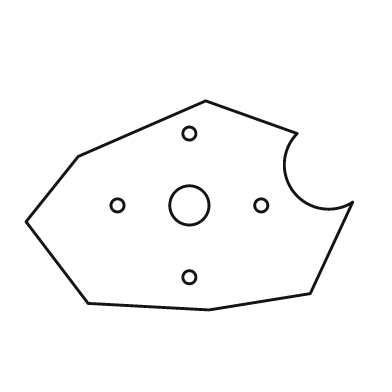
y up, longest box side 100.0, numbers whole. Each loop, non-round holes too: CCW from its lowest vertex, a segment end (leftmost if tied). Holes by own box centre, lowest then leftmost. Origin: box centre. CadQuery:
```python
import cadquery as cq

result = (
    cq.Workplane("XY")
    .moveTo(6.0, -32.0)
    .lineTo(37.0, -27.0)
    .lineTo(50.0, 1.0)
    .threePointArc((32.0, 4.0), (33.0, 22.0))
    .lineTo(5.0, 32.0)
    .lineTo(-34.0, 15.0)
    .lineTo(-50.0, -5.0)
    .lineTo(-31.0, -30.0)
    .close()
    .moveTo(0.0, -22.0)
    .circle(2.0)
    .moveTo(-22.0, 0.0)
    .circle(2.0)
    .moveTo(0.0, 0.0)
    .circle(6.0)
    .moveTo(22.0, 0.0)
    .circle(2.0)
    .moveTo(0.0, 22.0)
    .circle(2.0)
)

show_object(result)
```